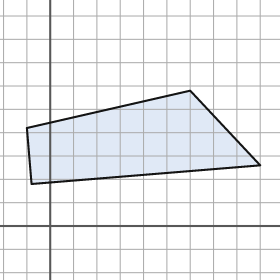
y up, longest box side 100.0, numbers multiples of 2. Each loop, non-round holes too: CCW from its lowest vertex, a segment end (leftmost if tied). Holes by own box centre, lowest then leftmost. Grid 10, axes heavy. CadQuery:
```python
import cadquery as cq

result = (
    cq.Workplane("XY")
    .moveTo(-8.0, 18.0)
    .lineTo(90.0, 26.0)
    .lineTo(60.0, 58.0)
    .lineTo(-10.0, 42.0)
    .close()
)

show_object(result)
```